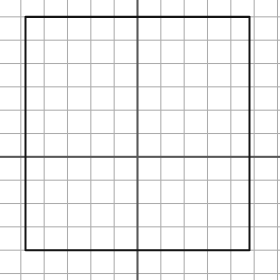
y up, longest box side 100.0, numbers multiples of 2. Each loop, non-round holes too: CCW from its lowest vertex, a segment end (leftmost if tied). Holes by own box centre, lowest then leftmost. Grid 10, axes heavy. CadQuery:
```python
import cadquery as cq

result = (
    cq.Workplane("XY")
    .moveTo(-48.0, -40.0)
    .lineTo(48.0, -40.0)
    .lineTo(48.0, 60.0)
    .lineTo(-48.0, 60.0)
    .close()
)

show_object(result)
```